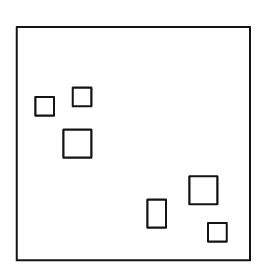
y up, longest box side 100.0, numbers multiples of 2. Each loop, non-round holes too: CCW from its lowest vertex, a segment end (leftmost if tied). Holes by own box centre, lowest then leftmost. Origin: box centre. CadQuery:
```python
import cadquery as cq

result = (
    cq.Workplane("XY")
    .moveTo(-50.0, -50.0)
    .lineTo(50.0, -50.0)
    .lineTo(50.0, 50.0)
    .lineTo(-50.0, 50.0)
    .close()
    .moveTo(32.0, -42.0)
    .lineTo(40.0, -42.0)
    .lineTo(40.0, -34.0)
    .lineTo(32.0, -34.0)
    .close()
    .moveTo(6.0, -36.0)
    .lineTo(14.0, -36.0)
    .lineTo(14.0, -24.0)
    .lineTo(6.0, -24.0)
    .close()
    .moveTo(24.0, -26.0)
    .lineTo(36.0, -26.0)
    .lineTo(36.0, -14.0)
    .lineTo(24.0, -14.0)
    .close()
    .moveTo(-30.0, -6.0)
    .lineTo(-18.0, -6.0)
    .lineTo(-18.0, 6.0)
    .lineTo(-30.0, 6.0)
    .close()
    .moveTo(-42.0, 12.0)
    .lineTo(-34.0, 12.0)
    .lineTo(-34.0, 20.0)
    .lineTo(-42.0, 20.0)
    .close()
    .moveTo(-26.0, 16.0)
    .lineTo(-18.0, 16.0)
    .lineTo(-18.0, 24.0)
    .lineTo(-26.0, 24.0)
    .close()
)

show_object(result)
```